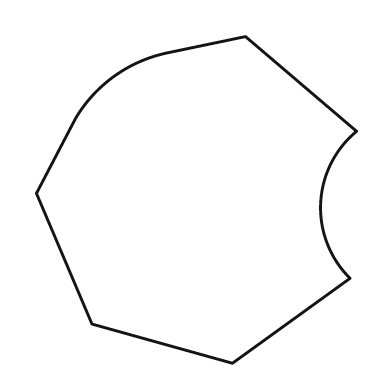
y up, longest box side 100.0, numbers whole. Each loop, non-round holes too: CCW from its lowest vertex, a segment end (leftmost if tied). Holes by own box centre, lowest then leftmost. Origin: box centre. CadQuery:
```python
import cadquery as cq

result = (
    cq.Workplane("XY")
    .moveTo(11.0, -50.0)
    .lineTo(47.0, -24.0)
    .threePointArc((38.0, -1.0), (49.0, 21.0))
    .lineTo(15.0, 50.0)
    .lineTo(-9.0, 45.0)
    .threePointArc((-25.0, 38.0), (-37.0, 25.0))
    .lineTo(-49.0, 2.0)
    .lineTo(-32.0, -38.0)
    .close()
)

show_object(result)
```